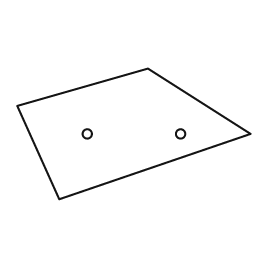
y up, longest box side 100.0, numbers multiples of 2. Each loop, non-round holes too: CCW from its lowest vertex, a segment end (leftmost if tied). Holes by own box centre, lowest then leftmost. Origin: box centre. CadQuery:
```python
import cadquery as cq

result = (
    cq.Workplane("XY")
    .moveTo(-32.0, -28.0)
    .lineTo(50.0, 0.0)
    .lineTo(6.0, 28.0)
    .lineTo(-50.0, 12.0)
    .close()
    .moveTo(-20.0, 0.0)
    .circle(2.0)
    .moveTo(20.0, 0.0)
    .circle(2.0)
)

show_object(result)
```